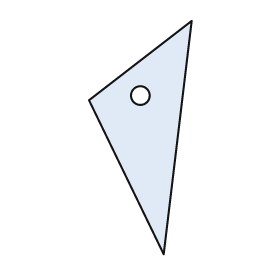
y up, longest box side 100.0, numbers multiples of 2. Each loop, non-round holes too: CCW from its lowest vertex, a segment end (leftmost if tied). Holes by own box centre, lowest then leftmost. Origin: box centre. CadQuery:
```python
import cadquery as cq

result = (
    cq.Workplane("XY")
    .moveTo(10.0, -50.0)
    .lineTo(22.0, 50.0)
    .lineTo(-22.0, 16.0)
    .close()
    .moveTo(0.0, 18.0)
    .circle(4.0)
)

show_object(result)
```